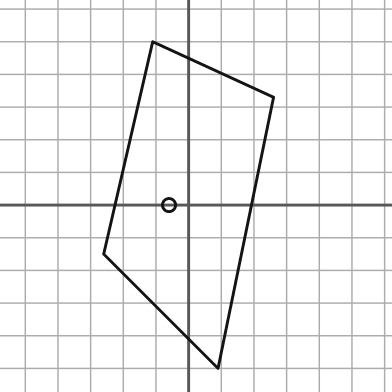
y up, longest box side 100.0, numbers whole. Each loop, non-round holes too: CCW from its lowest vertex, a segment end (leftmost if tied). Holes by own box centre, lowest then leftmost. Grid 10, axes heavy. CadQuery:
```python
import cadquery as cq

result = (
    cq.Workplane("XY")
    .moveTo(9.0, -50.0)
    .lineTo(26.0, 33.0)
    .lineTo(-11.0, 50.0)
    .lineTo(-26.0, -15.0)
    .close()
    .moveTo(-6.0, 0.0)
    .circle(2.0)
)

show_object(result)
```